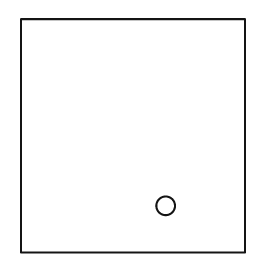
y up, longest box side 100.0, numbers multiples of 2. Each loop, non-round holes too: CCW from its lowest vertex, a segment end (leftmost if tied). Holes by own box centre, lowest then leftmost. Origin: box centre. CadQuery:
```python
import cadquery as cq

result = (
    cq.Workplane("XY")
    .moveTo(-48.0, -50.0)
    .lineTo(48.0, -50.0)
    .lineTo(48.0, 50.0)
    .lineTo(-48.0, 50.0)
    .close()
    .moveTo(14.0, -30.0)
    .circle(4.0)
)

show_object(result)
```